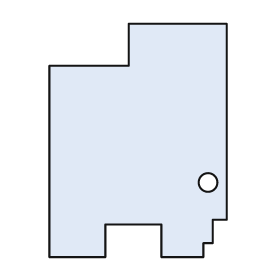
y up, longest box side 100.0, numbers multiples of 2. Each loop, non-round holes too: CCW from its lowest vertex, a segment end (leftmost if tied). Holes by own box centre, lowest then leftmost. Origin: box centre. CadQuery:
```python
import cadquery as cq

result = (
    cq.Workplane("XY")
    .moveTo(-38.0, -50.0)
    .lineTo(-14.0, -50.0)
    .lineTo(-14.0, -36.0)
    .lineTo(10.0, -36.0)
    .lineTo(10.0, -50.0)
    .lineTo(28.0, -50.0)
    .lineTo(28.0, -44.0)
    .lineTo(32.0, -44.0)
    .lineTo(32.0, -34.0)
    .lineTo(38.0, -34.0)
    .lineTo(38.0, 50.0)
    .lineTo(-4.0, 50.0)
    .lineTo(-4.0, 32.0)
    .lineTo(-38.0, 32.0)
    .close()
    .moveTo(30.0, -18.0)
    .circle(4.0)
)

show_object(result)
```